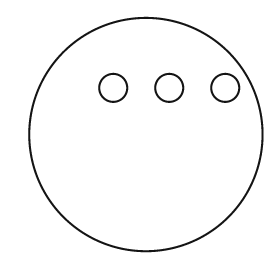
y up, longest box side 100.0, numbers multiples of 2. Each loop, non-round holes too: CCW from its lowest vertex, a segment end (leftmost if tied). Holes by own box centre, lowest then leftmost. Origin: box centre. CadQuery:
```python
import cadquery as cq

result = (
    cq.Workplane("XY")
    .moveTo(0.0, 0.0)
    .circle(50.0)
    .moveTo(-14.0, 20.0)
    .circle(6.0)
    .moveTo(10.0, 20.0)
    .circle(6.0)
    .moveTo(34.0, 20.0)
    .circle(6.0)
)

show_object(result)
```